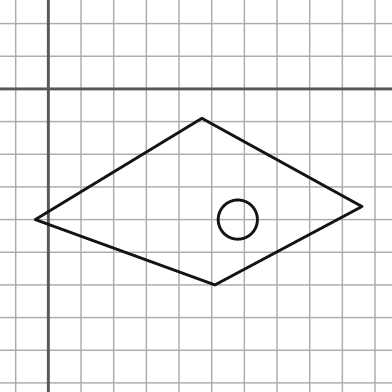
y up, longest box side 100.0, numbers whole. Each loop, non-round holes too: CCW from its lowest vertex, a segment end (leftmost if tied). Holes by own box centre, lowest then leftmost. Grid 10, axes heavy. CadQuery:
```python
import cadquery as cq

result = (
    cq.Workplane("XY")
    .moveTo(51.0, -60.0)
    .lineTo(96.0, -36.0)
    .lineTo(47.0, -9.0)
    .lineTo(-4.0, -40.0)
    .close()
    .moveTo(58.0, -40.0)
    .circle(6.0)
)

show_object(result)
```